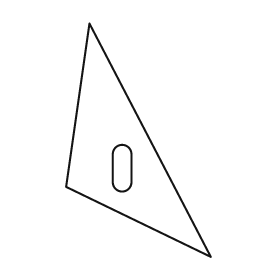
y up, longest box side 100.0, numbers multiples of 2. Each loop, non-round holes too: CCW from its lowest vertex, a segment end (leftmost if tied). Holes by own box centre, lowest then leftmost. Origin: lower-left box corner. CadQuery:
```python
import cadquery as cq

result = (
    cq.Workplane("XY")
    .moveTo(62.0, 0.0)
    .lineTo(10.0, 100.0)
    .lineTo(0.0, 30.0)
    .close()
    .moveTo(20.0, 32.0)
    .threePointArc((24.0, 28.0), (28.0, 32.0))
    .lineTo(28.0, 44.0)
    .threePointArc((24.0, 48.0), (20.0, 44.0))
    .close()
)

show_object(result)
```